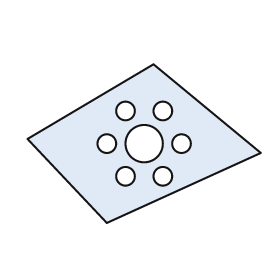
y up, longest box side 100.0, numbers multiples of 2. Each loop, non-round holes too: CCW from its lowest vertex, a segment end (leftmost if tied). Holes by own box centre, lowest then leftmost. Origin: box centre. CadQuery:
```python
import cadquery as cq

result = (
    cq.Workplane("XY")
    .moveTo(-16.0, -34.0)
    .lineTo(50.0, -4.0)
    .lineTo(4.0, 34.0)
    .lineTo(-50.0, 2.0)
    .close()
    .moveTo(-8.0, -14.0)
    .circle(4.0)
    .moveTo(8.0, -14.0)
    .circle(4.0)
    .moveTo(-16.0, 0.0)
    .circle(4.0)
    .moveTo(0.0, 0.0)
    .circle(8.0)
    .moveTo(16.0, 0.0)
    .circle(4.0)
    .moveTo(-8.0, 14.0)
    .circle(4.0)
    .moveTo(8.0, 14.0)
    .circle(4.0)
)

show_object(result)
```